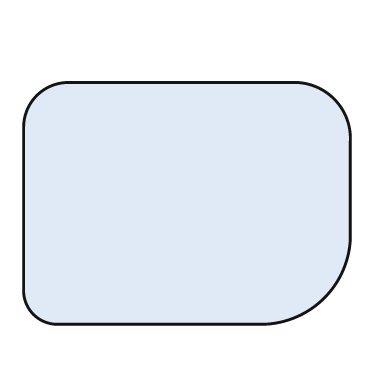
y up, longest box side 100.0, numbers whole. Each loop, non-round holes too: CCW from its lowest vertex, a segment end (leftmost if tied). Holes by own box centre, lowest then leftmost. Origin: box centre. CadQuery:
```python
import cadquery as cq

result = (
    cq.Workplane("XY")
    .moveTo(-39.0, -37.0)
    .lineTo(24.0, -37.0)
    .threePointArc((42.0, -29.0), (50.0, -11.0))
    .lineTo(50.0, 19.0)
    .threePointArc((45.0, 32.0), (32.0, 37.0))
    .lineTo(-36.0, 37.0)
    .threePointArc((-46.0, 33.0), (-50.0, 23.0))
    .lineTo(-50.0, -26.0)
    .threePointArc((-47.0, -34.0), (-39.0, -37.0))
    .close()
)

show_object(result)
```